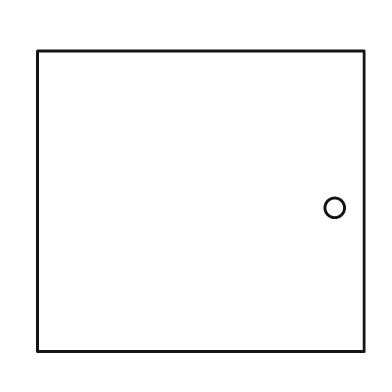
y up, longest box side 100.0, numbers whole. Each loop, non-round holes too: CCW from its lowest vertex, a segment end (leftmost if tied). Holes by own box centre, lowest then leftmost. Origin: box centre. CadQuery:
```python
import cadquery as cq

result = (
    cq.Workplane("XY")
    .moveTo(-50.0, -46.0)
    .lineTo(50.0, -46.0)
    .lineTo(50.0, 46.0)
    .lineTo(-50.0, 46.0)
    .close()
    .moveTo(41.0, -2.0)
    .circle(3.0)
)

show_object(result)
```